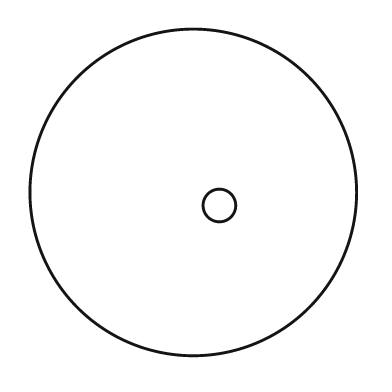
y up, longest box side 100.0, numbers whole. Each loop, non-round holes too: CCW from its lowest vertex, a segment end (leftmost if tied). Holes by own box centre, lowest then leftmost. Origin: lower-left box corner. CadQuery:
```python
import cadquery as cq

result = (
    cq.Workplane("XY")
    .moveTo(50.0, 50.0)
    .circle(50.0)
    .moveTo(58.0, 46.0)
    .circle(5.0)
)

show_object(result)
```